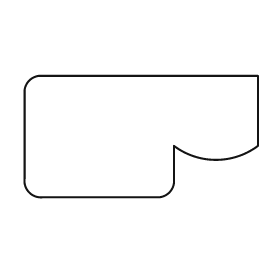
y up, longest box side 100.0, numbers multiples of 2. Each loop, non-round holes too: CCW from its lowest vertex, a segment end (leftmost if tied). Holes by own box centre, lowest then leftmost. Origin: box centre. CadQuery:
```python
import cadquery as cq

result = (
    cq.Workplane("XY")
    .moveTo(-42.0, -26.0)
    .lineTo(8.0, -26.0)
    .threePointArc((12.0, -24.0), (14.0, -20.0))
    .lineTo(14.0, -4.0)
    .threePointArc((32.0, -10.0), (50.0, -4.0))
    .lineTo(50.0, 26.0)
    .lineTo(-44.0, 26.0)
    .threePointArc((-48.0, 24.0), (-50.0, 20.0))
    .lineTo(-50.0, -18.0)
    .threePointArc((-48.0, -24.0), (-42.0, -26.0))
    .close()
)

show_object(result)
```